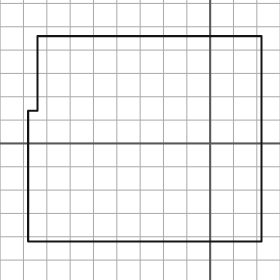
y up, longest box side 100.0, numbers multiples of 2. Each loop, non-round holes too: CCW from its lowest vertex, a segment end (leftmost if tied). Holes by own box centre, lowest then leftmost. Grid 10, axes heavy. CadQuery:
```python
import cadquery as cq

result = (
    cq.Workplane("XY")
    .moveTo(-78.0, -42.0)
    .lineTo(22.0, -42.0)
    .lineTo(22.0, 46.0)
    .lineTo(-74.0, 46.0)
    .lineTo(-74.0, 14.0)
    .lineTo(-78.0, 14.0)
    .close()
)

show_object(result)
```